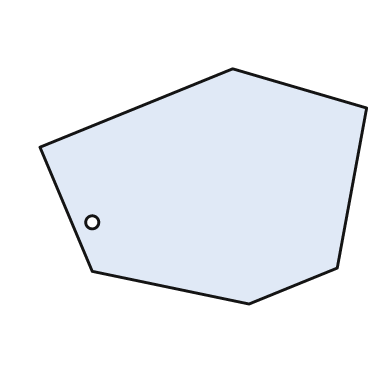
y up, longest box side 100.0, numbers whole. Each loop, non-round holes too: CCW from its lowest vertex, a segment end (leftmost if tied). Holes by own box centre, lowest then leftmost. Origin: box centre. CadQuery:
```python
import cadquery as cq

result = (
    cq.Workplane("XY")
    .moveTo(14.0, -36.0)
    .lineTo(41.0, -25.0)
    .lineTo(50.0, 24.0)
    .lineTo(9.0, 36.0)
    .lineTo(-50.0, 12.0)
    .lineTo(-34.0, -26.0)
    .close()
    .moveTo(-34.0, -11.0)
    .circle(2.0)
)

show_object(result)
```